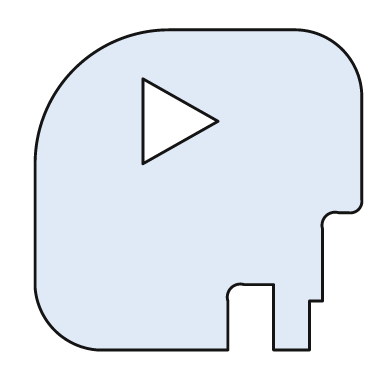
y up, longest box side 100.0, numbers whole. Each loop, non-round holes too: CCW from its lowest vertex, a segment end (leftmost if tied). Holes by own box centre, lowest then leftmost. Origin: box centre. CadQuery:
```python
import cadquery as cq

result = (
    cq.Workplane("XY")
    .moveTo(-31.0, -49.0)
    .lineTo(9.0, -49.0)
    .lineTo(9.0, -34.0)
    .threePointArc((10.0, -30.0), (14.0, -29.0))
    .lineTo(23.0, -29.0)
    .lineTo(23.0, -49.0)
    .lineTo(34.0, -49.0)
    .lineTo(34.0, -34.0)
    .lineTo(38.0, -34.0)
    .lineTo(38.0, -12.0)
    .threePointArc((39.0, -8.0), (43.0, -7.0))
    .lineTo(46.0, -7.0)
    .threePointArc((49.0, -6.0), (50.0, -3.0))
    .lineTo(50.0, 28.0)
    .threePointArc((44.0, 43.0), (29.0, 49.0))
    .lineTo(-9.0, 49.0)
    .threePointArc((-38.0, 37.0), (-50.0, 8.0))
    .lineTo(-50.0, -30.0)
    .threePointArc((-44.0, -43.0), (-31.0, -49.0))
    .close()
    .moveTo(-17.0, 8.0)
    .lineTo(6.0, 21.0)
    .lineTo(-17.0, 34.0)
    .close()
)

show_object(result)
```